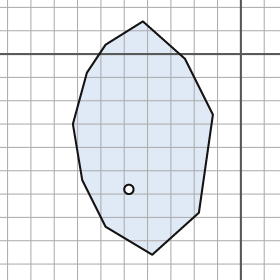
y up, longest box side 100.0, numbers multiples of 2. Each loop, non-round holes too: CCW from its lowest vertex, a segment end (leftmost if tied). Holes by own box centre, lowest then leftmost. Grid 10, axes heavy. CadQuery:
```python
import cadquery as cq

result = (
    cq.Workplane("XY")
    .moveTo(-38.0, -86.0)
    .lineTo(-18.0, -68.0)
    .lineTo(-12.0, -26.0)
    .lineTo(-24.0, -2.0)
    .lineTo(-42.0, 14.0)
    .lineTo(-58.0, 4.0)
    .lineTo(-66.0, -8.0)
    .lineTo(-72.0, -30.0)
    .lineTo(-68.0, -54.0)
    .lineTo(-58.0, -74.0)
    .close()
    .moveTo(-48.0, -58.0)
    .circle(2.0)
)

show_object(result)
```